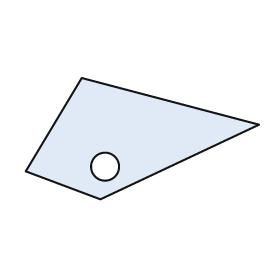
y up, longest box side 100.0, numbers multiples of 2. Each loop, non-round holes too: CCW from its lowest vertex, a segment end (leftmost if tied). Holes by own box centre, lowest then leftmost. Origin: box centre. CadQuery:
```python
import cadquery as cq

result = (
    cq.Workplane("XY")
    .moveTo(-18.0, -26.0)
    .lineTo(50.0, 6.0)
    .lineTo(-26.0, 26.0)
    .lineTo(-50.0, -14.0)
    .close()
    .moveTo(-16.0, -12.0)
    .circle(6.0)
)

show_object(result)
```